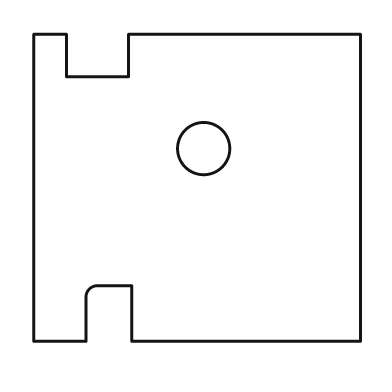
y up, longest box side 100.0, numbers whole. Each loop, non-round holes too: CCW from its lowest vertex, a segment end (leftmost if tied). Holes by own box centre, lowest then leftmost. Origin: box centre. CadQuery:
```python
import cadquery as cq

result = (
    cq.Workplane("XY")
    .moveTo(-50.0, -47.0)
    .lineTo(-34.0, -47.0)
    .lineTo(-34.0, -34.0)
    .threePointArc((-33.0, -31.0), (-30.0, -30.0))
    .lineTo(-20.0, -30.0)
    .lineTo(-20.0, -47.0)
    .lineTo(50.0, -47.0)
    .lineTo(50.0, 47.0)
    .lineTo(-21.0, 47.0)
    .lineTo(-21.0, 34.0)
    .lineTo(-40.0, 34.0)
    .lineTo(-40.0, 47.0)
    .lineTo(-50.0, 47.0)
    .close()
    .moveTo(2.0, 12.0)
    .circle(8.0)
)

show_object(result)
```